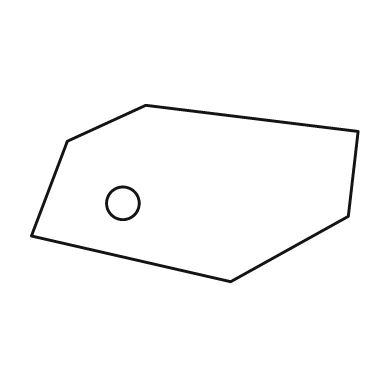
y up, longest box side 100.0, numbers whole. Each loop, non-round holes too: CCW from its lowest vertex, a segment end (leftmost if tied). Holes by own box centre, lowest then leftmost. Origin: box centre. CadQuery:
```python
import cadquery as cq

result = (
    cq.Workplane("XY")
    .moveTo(11.0, -27.0)
    .lineTo(47.0, -7.0)
    .lineTo(50.0, 19.0)
    .lineTo(-15.0, 27.0)
    .lineTo(-39.0, 16.0)
    .lineTo(-50.0, -13.0)
    .close()
    .moveTo(-22.0, -3.0)
    .circle(5.0)
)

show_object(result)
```